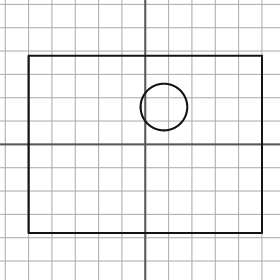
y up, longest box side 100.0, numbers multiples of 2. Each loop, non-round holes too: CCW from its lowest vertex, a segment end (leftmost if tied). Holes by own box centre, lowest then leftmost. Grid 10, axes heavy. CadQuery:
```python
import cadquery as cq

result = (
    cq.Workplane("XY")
    .moveTo(-50.0, -38.0)
    .lineTo(50.0, -38.0)
    .lineTo(50.0, 38.0)
    .lineTo(-50.0, 38.0)
    .close()
    .moveTo(8.0, 16.0)
    .circle(10.0)
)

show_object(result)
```